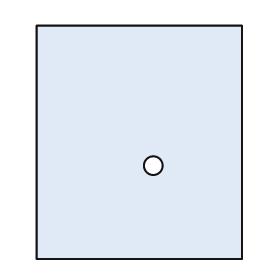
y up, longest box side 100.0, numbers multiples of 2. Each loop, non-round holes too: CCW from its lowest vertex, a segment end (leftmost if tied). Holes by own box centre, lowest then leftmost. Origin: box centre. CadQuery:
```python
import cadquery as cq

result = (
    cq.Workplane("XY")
    .moveTo(-44.0, -50.0)
    .lineTo(44.0, -50.0)
    .lineTo(44.0, 50.0)
    .lineTo(-44.0, 50.0)
    .close()
    .moveTo(6.0, -10.0)
    .circle(4.0)
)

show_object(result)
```